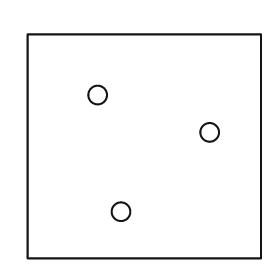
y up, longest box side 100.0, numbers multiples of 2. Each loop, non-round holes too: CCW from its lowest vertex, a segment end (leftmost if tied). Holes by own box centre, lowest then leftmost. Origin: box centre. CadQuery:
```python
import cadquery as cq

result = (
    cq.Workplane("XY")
    .moveTo(-50.0, -48.0)
    .lineTo(50.0, -48.0)
    .lineTo(50.0, 48.0)
    .lineTo(-50.0, 48.0)
    .close()
    .moveTo(-10.0, -28.0)
    .circle(4.0)
    .moveTo(28.0, 6.0)
    .circle(4.0)
    .moveTo(-20.0, 22.0)
    .circle(4.0)
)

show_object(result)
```